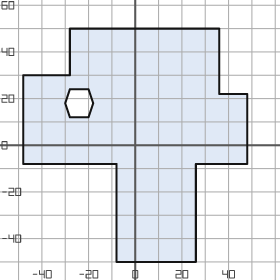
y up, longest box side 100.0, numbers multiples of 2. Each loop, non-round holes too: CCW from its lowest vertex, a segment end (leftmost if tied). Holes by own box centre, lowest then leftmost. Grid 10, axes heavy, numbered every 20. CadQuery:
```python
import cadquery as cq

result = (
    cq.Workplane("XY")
    .moveTo(-8.0, -50.0)
    .lineTo(26.0, -50.0)
    .lineTo(26.0, -8.0)
    .lineTo(48.0, -8.0)
    .lineTo(48.0, 22.0)
    .lineTo(36.0, 22.0)
    .lineTo(36.0, 50.0)
    .lineTo(-28.0, 50.0)
    .lineTo(-28.0, 30.0)
    .lineTo(-48.0, 30.0)
    .lineTo(-48.0, -8.0)
    .lineTo(-8.0, -8.0)
    .close()
    .moveTo(-28.0, 12.0)
    .lineTo(-20.0, 12.0)
    .lineTo(-18.0, 18.0)
    .lineTo(-20.0, 24.0)
    .lineTo(-28.0, 24.0)
    .lineTo(-30.0, 18.0)
    .close()
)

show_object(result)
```